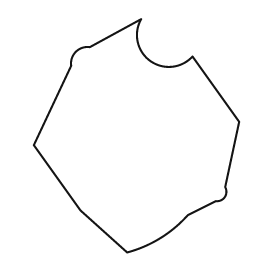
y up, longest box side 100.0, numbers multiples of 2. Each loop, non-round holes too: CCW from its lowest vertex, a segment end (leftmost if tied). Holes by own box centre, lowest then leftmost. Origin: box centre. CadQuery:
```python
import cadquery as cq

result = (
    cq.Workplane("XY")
    .moveTo(-4.0, -50.0)
    .threePointArc((10.0, -44.0), (22.0, -34.0))
    .lineTo(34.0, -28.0)
    .threePointArc((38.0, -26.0), (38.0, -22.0))
    .lineTo(44.0, 6.0)
    .lineTo(24.0, 34.0)
    .threePointArc((6.0, 32.0), (2.0, 50.0))
    .lineTo(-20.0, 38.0)
    .threePointArc((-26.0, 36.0), (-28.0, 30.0))
    .lineTo(-44.0, -4.0)
    .lineTo(-24.0, -32.0)
    .close()
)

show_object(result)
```